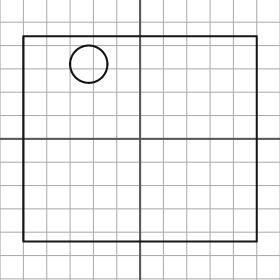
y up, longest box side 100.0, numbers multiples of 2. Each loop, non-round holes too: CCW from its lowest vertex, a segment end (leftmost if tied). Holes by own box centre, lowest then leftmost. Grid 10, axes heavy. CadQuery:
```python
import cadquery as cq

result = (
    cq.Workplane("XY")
    .moveTo(-50.0, -44.0)
    .lineTo(50.0, -44.0)
    .lineTo(50.0, 44.0)
    .lineTo(-50.0, 44.0)
    .close()
    .moveTo(-22.0, 32.0)
    .circle(8.0)
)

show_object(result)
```